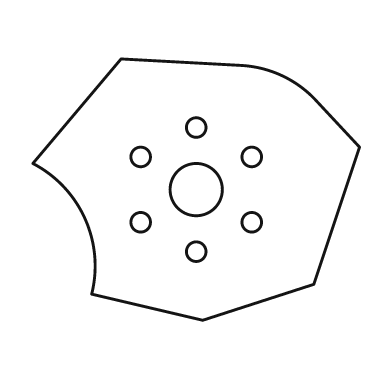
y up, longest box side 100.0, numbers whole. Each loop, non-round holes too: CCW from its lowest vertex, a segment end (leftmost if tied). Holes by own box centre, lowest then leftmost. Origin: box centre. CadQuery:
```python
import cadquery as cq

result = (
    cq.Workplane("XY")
    .moveTo(2.0, -40.0)
    .lineTo(36.0, -29.0)
    .lineTo(50.0, 13.0)
    .lineTo(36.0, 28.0)
    .threePointArc((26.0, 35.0), (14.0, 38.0))
    .lineTo(-23.0, 40.0)
    .lineTo(-50.0, 8.0)
    .threePointArc((-34.0, -9.0), (-32.0, -32.0))
    .close()
    .moveTo(0.0, -19.0)
    .circle(3.0)
    .moveTo(-17.0, -10.0)
    .circle(3.0)
    .moveTo(17.0, -10.0)
    .circle(3.0)
    .moveTo(0.0, 0.0)
    .circle(8.0)
    .moveTo(-17.0, 10.0)
    .circle(3.0)
    .moveTo(17.0, 10.0)
    .circle(3.0)
    .moveTo(0.0, 19.0)
    .circle(3.0)
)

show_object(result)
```